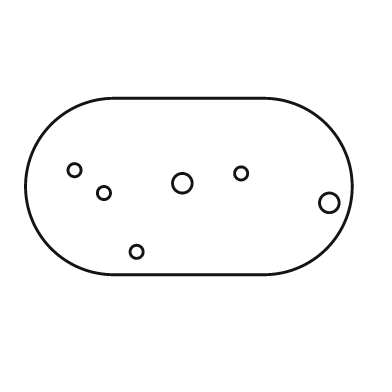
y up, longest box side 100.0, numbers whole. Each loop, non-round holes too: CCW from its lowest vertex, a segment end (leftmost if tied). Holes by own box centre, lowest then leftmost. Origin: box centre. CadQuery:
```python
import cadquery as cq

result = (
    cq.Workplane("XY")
    .moveTo(-23.0, -27.0)
    .lineTo(23.0, -27.0)
    .threePointArc((50.0, 0.0), (23.0, 27.0))
    .lineTo(-23.0, 27.0)
    .threePointArc((-50.0, 0.0), (-23.0, -27.0))
    .close()
    .moveTo(-16.0, -20.0)
    .circle(2.0)
    .moveTo(43.0, -5.0)
    .circle(3.0)
    .moveTo(-26.0, -2.0)
    .circle(2.0)
    .moveTo(-2.0, 1.0)
    .circle(3.0)
    .moveTo(16.0, 4.0)
    .circle(2.0)
    .moveTo(-35.0, 5.0)
    .circle(2.0)
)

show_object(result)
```